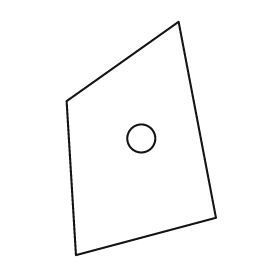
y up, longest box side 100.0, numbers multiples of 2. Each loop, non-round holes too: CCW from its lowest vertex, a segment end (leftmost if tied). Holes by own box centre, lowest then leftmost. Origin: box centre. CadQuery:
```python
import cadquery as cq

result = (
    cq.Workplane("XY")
    .moveTo(-28.0, -50.0)
    .lineTo(32.0, -34.0)
    .lineTo(16.0, 50.0)
    .lineTo(-32.0, 16.0)
    .close()
    .moveTo(0.0, 0.0)
    .circle(6.0)
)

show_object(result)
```